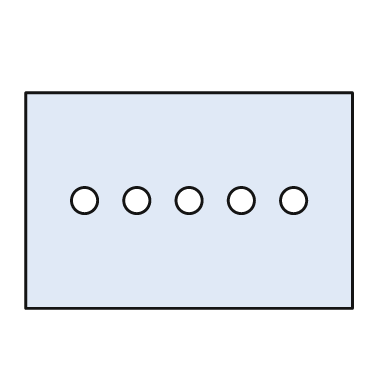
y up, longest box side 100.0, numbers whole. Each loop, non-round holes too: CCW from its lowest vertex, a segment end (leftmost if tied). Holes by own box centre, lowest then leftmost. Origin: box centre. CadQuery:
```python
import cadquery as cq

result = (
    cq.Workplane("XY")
    .moveTo(-50.0, -33.0)
    .lineTo(50.0, -33.0)
    .lineTo(50.0, 33.0)
    .lineTo(-50.0, 33.0)
    .close()
    .moveTo(-32.0, 0.0)
    .circle(4.0)
    .moveTo(-16.0, 0.0)
    .circle(4.0)
    .moveTo(0.0, 0.0)
    .circle(4.0)
    .moveTo(16.0, 0.0)
    .circle(4.0)
    .moveTo(32.0, 0.0)
    .circle(4.0)
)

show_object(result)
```